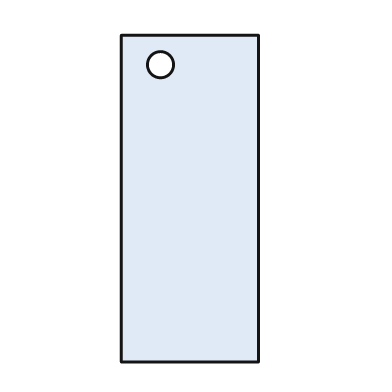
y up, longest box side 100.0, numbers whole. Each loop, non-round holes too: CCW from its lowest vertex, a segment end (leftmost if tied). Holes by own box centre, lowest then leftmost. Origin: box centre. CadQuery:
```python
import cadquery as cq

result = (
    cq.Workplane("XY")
    .moveTo(-21.0, -50.0)
    .lineTo(21.0, -50.0)
    .lineTo(21.0, 50.0)
    .lineTo(-21.0, 50.0)
    .close()
    .moveTo(-9.0, 41.0)
    .circle(4.0)
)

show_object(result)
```